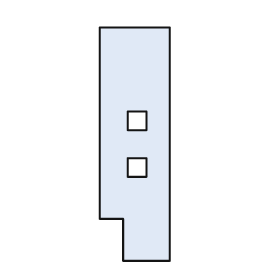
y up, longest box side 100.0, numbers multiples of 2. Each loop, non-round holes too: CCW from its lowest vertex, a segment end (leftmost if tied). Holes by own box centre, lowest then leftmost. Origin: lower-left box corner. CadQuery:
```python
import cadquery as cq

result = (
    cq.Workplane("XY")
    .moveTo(10.0, 0.0)
    .lineTo(30.0, 0.0)
    .lineTo(30.0, 100.0)
    .lineTo(0.0, 100.0)
    .lineTo(0.0, 18.0)
    .lineTo(10.0, 18.0)
    .close()
    .moveTo(12.0, 36.0)
    .lineTo(20.0, 36.0)
    .lineTo(20.0, 44.0)
    .lineTo(12.0, 44.0)
    .close()
    .moveTo(12.0, 56.0)
    .lineTo(20.0, 56.0)
    .lineTo(20.0, 64.0)
    .lineTo(12.0, 64.0)
    .close()
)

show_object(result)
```